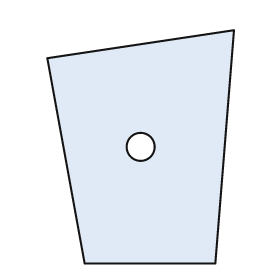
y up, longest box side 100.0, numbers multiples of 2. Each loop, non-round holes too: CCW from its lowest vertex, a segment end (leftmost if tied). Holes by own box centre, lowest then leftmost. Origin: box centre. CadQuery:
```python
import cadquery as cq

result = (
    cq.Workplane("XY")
    .moveTo(-24.0, -50.0)
    .lineTo(32.0, -50.0)
    .lineTo(40.0, 50.0)
    .lineTo(-40.0, 38.0)
    .close()
    .moveTo(0.0, 0.0)
    .circle(6.0)
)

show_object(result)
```